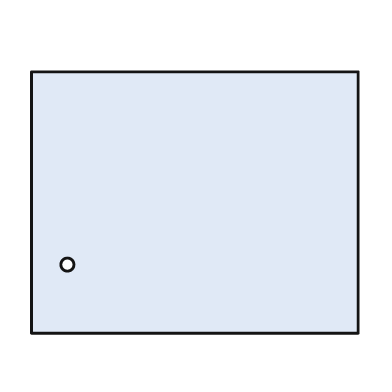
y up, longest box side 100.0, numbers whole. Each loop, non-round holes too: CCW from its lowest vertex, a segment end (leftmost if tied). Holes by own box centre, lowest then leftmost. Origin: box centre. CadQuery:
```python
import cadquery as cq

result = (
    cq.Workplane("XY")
    .moveTo(-50.0, -40.0)
    .lineTo(50.0, -40.0)
    .lineTo(50.0, 40.0)
    .lineTo(-50.0, 40.0)
    .close()
    .moveTo(-39.0, -19.0)
    .circle(2.0)
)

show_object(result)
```